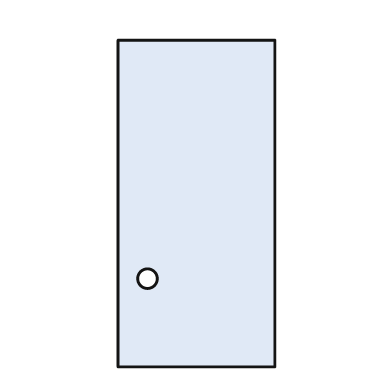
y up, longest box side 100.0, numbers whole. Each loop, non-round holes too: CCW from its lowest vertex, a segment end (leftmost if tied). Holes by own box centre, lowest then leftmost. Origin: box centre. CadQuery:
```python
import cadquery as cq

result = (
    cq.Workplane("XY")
    .moveTo(-24.0, -50.0)
    .lineTo(24.0, -50.0)
    .lineTo(24.0, 50.0)
    .lineTo(-24.0, 50.0)
    .close()
    .moveTo(-15.0, -23.0)
    .circle(3.0)
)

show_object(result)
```